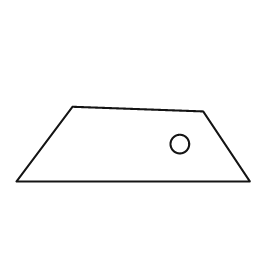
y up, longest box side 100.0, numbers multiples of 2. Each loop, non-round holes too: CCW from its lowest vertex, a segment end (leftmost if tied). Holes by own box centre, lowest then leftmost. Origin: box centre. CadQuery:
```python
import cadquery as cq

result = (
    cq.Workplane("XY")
    .moveTo(-50.0, -16.0)
    .lineTo(50.0, -16.0)
    .lineTo(30.0, 14.0)
    .lineTo(-26.0, 16.0)
    .close()
    .moveTo(20.0, 0.0)
    .circle(4.0)
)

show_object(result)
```